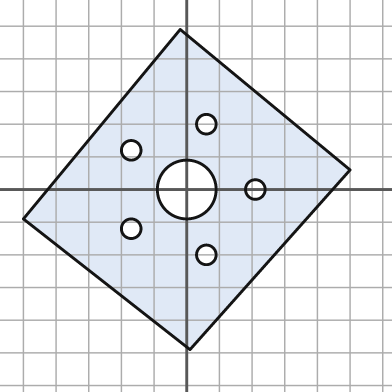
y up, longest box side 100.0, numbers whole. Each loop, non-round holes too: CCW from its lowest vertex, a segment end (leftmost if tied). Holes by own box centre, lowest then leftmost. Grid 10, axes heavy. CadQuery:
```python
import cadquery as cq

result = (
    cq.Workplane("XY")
    .moveTo(1.0, -49.0)
    .lineTo(50.0, 6.0)
    .lineTo(-2.0, 49.0)
    .lineTo(-50.0, -9.0)
    .close()
    .moveTo(6.0, -20.0)
    .circle(3.0)
    .moveTo(-17.0, -12.0)
    .circle(3.0)
    .moveTo(0.0, 0.0)
    .circle(9.0)
    .moveTo(21.0, 0.0)
    .circle(3.0)
    .moveTo(-17.0, 12.0)
    .circle(3.0)
    .moveTo(6.0, 20.0)
    .circle(3.0)
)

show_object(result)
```